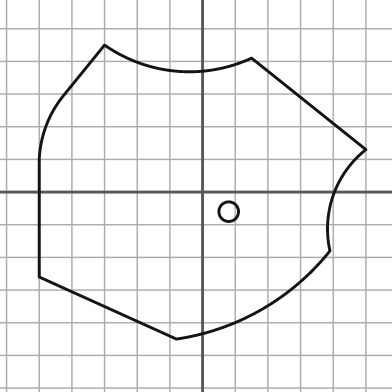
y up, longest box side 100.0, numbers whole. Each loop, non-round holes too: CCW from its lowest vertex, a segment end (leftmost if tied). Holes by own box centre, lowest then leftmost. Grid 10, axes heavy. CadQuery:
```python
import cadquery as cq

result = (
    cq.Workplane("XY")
    .moveTo(-8.0, -45.0)
    .threePointArc((18.0, -36.0), (39.0, -18.0))
    .threePointArc((40.0, -1.0), (50.0, 13.0))
    .lineTo(15.0, 41.0)
    .threePointArc((-8.0, 37.0), (-30.0, 45.0))
    .lineTo(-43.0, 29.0)
    .threePointArc((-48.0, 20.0), (-50.0, 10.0))
    .lineTo(-50.0, -26.0)
    .close()
    .moveTo(8.0, -6.0)
    .circle(3.0)
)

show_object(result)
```